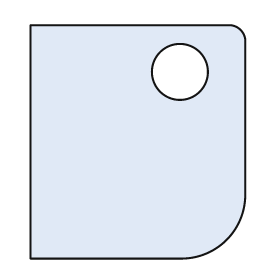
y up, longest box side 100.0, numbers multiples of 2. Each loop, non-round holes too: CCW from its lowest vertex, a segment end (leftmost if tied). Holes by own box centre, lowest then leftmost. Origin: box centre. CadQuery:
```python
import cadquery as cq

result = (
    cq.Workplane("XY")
    .moveTo(-46.0, -50.0)
    .lineTo(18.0, -50.0)
    .threePointArc((38.0, -42.0), (46.0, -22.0))
    .lineTo(46.0, 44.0)
    .threePointArc((44.0, 48.0), (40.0, 50.0))
    .lineTo(-46.0, 50.0)
    .close()
    .moveTo(18.0, 30.0)
    .circle(12.0)
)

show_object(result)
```